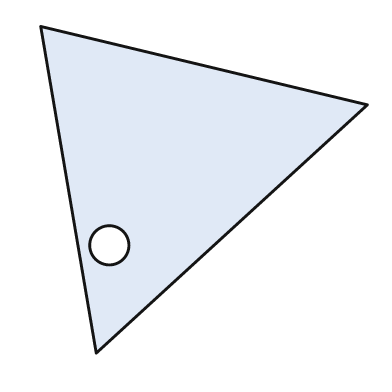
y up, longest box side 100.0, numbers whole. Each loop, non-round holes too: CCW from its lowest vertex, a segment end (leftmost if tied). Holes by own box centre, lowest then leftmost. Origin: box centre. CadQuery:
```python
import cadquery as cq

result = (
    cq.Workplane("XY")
    .moveTo(-33.0, -50.0)
    .lineTo(50.0, 26.0)
    .lineTo(-50.0, 50.0)
    .close()
    .moveTo(-29.0, -17.0)
    .circle(6.0)
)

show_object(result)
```